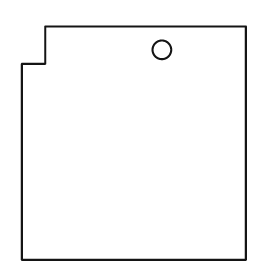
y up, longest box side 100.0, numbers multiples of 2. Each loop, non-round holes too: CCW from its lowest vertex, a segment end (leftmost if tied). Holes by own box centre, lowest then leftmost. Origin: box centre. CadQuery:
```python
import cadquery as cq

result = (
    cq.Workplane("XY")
    .moveTo(-48.0, -50.0)
    .lineTo(48.0, -50.0)
    .lineTo(48.0, 50.0)
    .lineTo(-38.0, 50.0)
    .lineTo(-38.0, 34.0)
    .lineTo(-48.0, 34.0)
    .close()
    .moveTo(12.0, 40.0)
    .circle(4.0)
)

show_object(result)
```